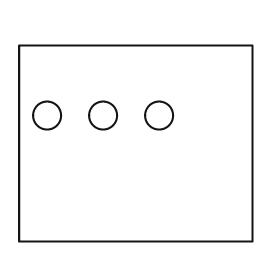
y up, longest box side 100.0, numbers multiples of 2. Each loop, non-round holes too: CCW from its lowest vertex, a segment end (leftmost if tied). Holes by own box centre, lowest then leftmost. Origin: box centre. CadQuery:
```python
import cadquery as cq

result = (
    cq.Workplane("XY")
    .moveTo(-50.0, -42.0)
    .lineTo(50.0, -42.0)
    .lineTo(50.0, 42.0)
    .lineTo(-50.0, 42.0)
    .close()
    .moveTo(-38.0, 12.0)
    .circle(6.0)
    .moveTo(-14.0, 12.0)
    .circle(6.0)
    .moveTo(10.0, 12.0)
    .circle(6.0)
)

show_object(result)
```